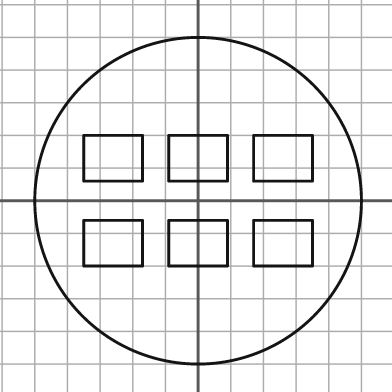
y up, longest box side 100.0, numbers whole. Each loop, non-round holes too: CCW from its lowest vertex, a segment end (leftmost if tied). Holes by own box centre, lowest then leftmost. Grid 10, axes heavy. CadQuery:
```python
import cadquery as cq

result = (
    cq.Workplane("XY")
    .moveTo(0.0, 0.0)
    .circle(50.0)
    .moveTo(-35.0, -20.0)
    .lineTo(-17.0, -20.0)
    .lineTo(-17.0, -6.0)
    .lineTo(-35.0, -6.0)
    .close()
    .moveTo(-9.0, -20.0)
    .lineTo(9.0, -20.0)
    .lineTo(9.0, -6.0)
    .lineTo(-9.0, -6.0)
    .close()
    .moveTo(17.0, -20.0)
    .lineTo(35.0, -20.0)
    .lineTo(35.0, -6.0)
    .lineTo(17.0, -6.0)
    .close()
    .moveTo(-35.0, 6.0)
    .lineTo(-17.0, 6.0)
    .lineTo(-17.0, 20.0)
    .lineTo(-35.0, 20.0)
    .close()
    .moveTo(-9.0, 6.0)
    .lineTo(9.0, 6.0)
    .lineTo(9.0, 20.0)
    .lineTo(-9.0, 20.0)
    .close()
    .moveTo(17.0, 6.0)
    .lineTo(35.0, 6.0)
    .lineTo(35.0, 20.0)
    .lineTo(17.0, 20.0)
    .close()
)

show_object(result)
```